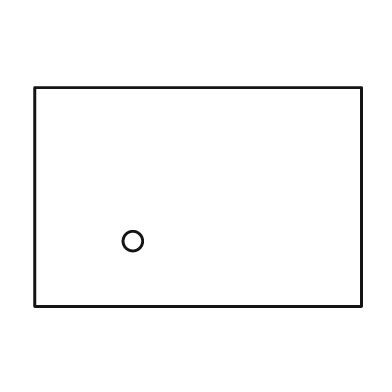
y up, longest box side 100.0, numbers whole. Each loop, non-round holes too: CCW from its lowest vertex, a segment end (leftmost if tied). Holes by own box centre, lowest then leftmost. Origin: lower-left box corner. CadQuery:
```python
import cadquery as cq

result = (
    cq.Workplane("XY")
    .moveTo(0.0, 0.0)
    .lineTo(100.0, 0.0)
    .lineTo(100.0, 67.0)
    .lineTo(0.0, 67.0)
    .close()
    .moveTo(30.0, 20.0)
    .circle(3.0)
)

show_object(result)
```